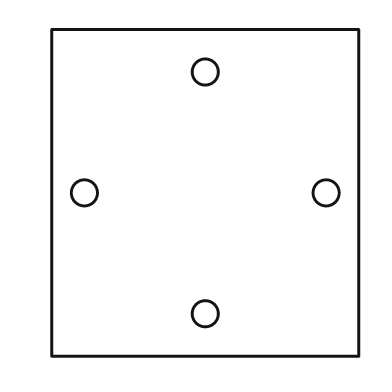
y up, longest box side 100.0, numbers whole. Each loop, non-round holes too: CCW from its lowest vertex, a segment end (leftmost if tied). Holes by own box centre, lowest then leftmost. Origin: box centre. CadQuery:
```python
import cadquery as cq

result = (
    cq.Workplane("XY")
    .moveTo(-47.0, -50.0)
    .lineTo(47.0, -50.0)
    .lineTo(47.0, 50.0)
    .lineTo(-47.0, 50.0)
    .close()
    .moveTo(0.0, -37.0)
    .circle(4.0)
    .moveTo(-37.0, 0.0)
    .circle(4.0)
    .moveTo(37.0, 0.0)
    .circle(4.0)
    .moveTo(0.0, 37.0)
    .circle(4.0)
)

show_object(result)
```